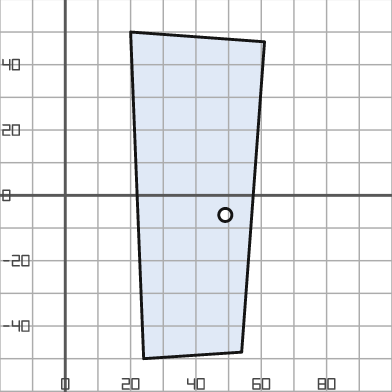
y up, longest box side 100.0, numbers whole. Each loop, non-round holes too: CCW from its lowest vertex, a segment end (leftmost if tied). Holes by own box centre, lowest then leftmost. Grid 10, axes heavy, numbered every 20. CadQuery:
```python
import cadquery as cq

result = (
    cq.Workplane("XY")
    .moveTo(24.0, -50.0)
    .lineTo(54.0, -48.0)
    .lineTo(61.0, 47.0)
    .lineTo(20.0, 50.0)
    .close()
    .moveTo(49.0, -6.0)
    .circle(2.0)
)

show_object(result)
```